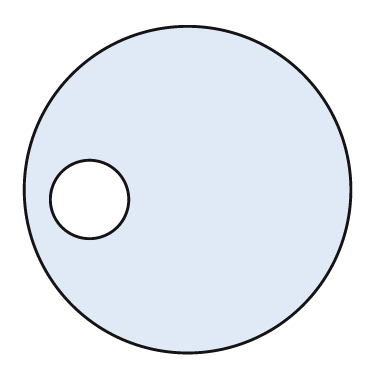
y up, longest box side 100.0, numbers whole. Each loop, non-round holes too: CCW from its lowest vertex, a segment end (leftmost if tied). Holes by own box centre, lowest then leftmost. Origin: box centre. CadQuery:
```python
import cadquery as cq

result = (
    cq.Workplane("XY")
    .moveTo(0.0, 0.0)
    .circle(50.0)
    .moveTo(-30.0, -3.0)
    .circle(12.0)
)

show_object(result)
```